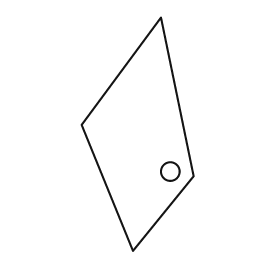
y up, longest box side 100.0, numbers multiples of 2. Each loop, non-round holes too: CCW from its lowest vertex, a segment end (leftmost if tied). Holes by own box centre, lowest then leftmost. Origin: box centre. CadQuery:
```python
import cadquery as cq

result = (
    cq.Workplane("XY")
    .moveTo(-2.0, -50.0)
    .lineTo(24.0, -18.0)
    .lineTo(10.0, 50.0)
    .lineTo(-24.0, 4.0)
    .close()
    .moveTo(14.0, -16.0)
    .circle(4.0)
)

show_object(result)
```